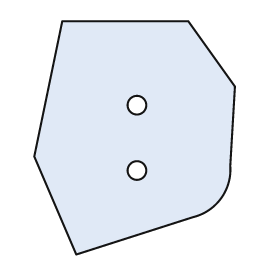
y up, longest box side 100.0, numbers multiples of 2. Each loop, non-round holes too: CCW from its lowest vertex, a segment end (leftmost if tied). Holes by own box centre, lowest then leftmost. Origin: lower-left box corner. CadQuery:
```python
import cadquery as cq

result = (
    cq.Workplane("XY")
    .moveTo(18.0, 0.0)
    .lineTo(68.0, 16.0)
    .threePointArc((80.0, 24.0), (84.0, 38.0))
    .lineTo(86.0, 72.0)
    .lineTo(66.0, 100.0)
    .lineTo(12.0, 100.0)
    .lineTo(0.0, 42.0)
    .close()
    .moveTo(44.0, 36.0)
    .circle(4.0)
    .moveTo(44.0, 64.0)
    .circle(4.0)
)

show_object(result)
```